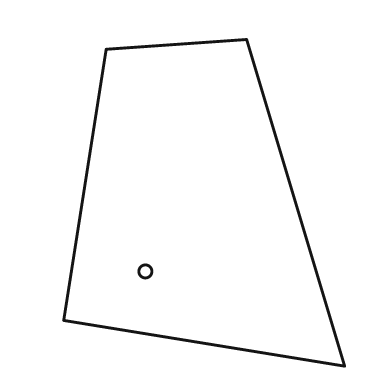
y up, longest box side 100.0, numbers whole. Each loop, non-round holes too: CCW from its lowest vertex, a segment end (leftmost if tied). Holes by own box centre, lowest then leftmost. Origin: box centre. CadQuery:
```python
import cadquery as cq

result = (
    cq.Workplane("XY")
    .moveTo(43.0, -50.0)
    .lineTo(13.0, 50.0)
    .lineTo(-30.0, 47.0)
    .lineTo(-43.0, -36.0)
    .close()
    .moveTo(-18.0, -21.0)
    .circle(2.0)
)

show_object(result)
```